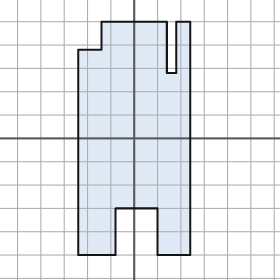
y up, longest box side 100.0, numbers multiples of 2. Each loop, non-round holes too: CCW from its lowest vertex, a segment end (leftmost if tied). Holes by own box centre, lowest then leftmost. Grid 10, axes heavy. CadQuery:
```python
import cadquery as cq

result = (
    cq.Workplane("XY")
    .moveTo(-24.0, -50.0)
    .lineTo(-8.0, -50.0)
    .lineTo(-8.0, -30.0)
    .lineTo(10.0, -30.0)
    .lineTo(10.0, -50.0)
    .lineTo(24.0, -50.0)
    .lineTo(24.0, 50.0)
    .lineTo(18.0, 50.0)
    .lineTo(18.0, 28.0)
    .lineTo(14.0, 28.0)
    .lineTo(14.0, 50.0)
    .lineTo(-14.0, 50.0)
    .lineTo(-14.0, 38.0)
    .lineTo(-24.0, 38.0)
    .close()
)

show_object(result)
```